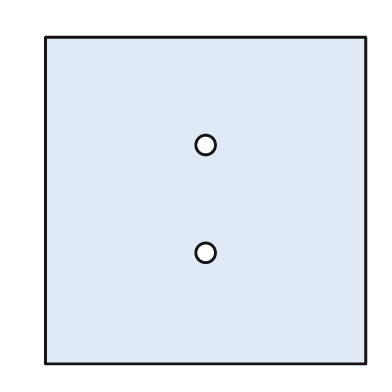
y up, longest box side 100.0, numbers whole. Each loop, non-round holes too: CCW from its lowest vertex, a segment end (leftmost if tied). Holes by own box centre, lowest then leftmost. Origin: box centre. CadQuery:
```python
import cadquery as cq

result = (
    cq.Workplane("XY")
    .moveTo(-49.0, -50.0)
    .lineTo(49.0, -50.0)
    .lineTo(49.0, 50.0)
    .lineTo(-49.0, 50.0)
    .close()
    .moveTo(0.0, -16.0)
    .circle(3.0)
    .moveTo(0.0, 17.0)
    .circle(3.0)
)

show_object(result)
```